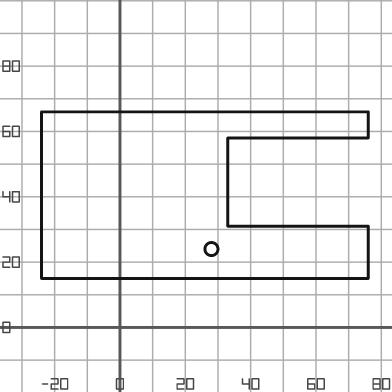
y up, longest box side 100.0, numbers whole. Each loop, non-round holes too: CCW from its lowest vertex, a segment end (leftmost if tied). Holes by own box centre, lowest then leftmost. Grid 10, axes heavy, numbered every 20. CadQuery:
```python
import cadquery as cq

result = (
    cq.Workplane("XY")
    .moveTo(-24.0, 15.0)
    .lineTo(76.0, 15.0)
    .lineTo(76.0, 31.0)
    .lineTo(33.0, 31.0)
    .lineTo(33.0, 58.0)
    .lineTo(76.0, 58.0)
    .lineTo(76.0, 66.0)
    .lineTo(-24.0, 66.0)
    .close()
    .moveTo(28.0, 24.0)
    .circle(2.0)
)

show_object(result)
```